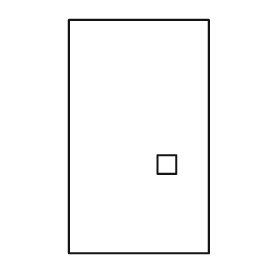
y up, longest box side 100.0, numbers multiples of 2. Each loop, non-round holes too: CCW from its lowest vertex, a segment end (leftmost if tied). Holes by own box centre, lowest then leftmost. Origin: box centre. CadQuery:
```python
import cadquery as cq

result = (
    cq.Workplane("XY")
    .moveTo(-30.0, -50.0)
    .lineTo(30.0, -50.0)
    .lineTo(30.0, 50.0)
    .lineTo(-30.0, 50.0)
    .close()
    .moveTo(8.0, -16.0)
    .lineTo(16.0, -16.0)
    .lineTo(16.0, -8.0)
    .lineTo(8.0, -8.0)
    .close()
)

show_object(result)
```